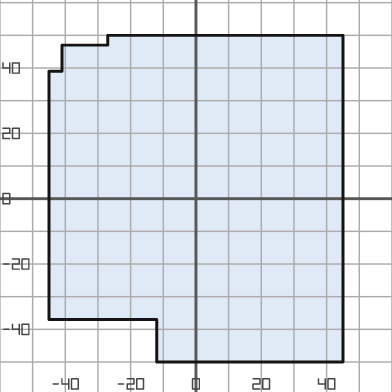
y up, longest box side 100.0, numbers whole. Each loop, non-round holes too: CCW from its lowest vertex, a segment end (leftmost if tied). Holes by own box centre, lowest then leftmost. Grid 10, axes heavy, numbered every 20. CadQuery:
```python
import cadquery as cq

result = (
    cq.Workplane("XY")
    .moveTo(-12.0, -50.0)
    .lineTo(45.0, -50.0)
    .lineTo(45.0, 50.0)
    .lineTo(-27.0, 50.0)
    .lineTo(-27.0, 47.0)
    .lineTo(-41.0, 47.0)
    .lineTo(-41.0, 39.0)
    .lineTo(-45.0, 39.0)
    .lineTo(-45.0, -37.0)
    .lineTo(-12.0, -37.0)
    .close()
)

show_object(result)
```